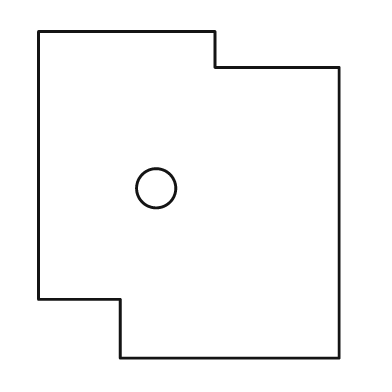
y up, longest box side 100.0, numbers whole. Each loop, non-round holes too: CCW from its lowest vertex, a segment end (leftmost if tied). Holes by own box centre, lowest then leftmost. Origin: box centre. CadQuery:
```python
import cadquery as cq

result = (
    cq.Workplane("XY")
    .moveTo(-21.0, -50.0)
    .lineTo(46.0, -50.0)
    .lineTo(46.0, 39.0)
    .lineTo(8.0, 39.0)
    .lineTo(8.0, 50.0)
    .lineTo(-46.0, 50.0)
    .lineTo(-46.0, -32.0)
    .lineTo(-21.0, -32.0)
    .close()
    .moveTo(-10.0, 2.0)
    .circle(6.0)
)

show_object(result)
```